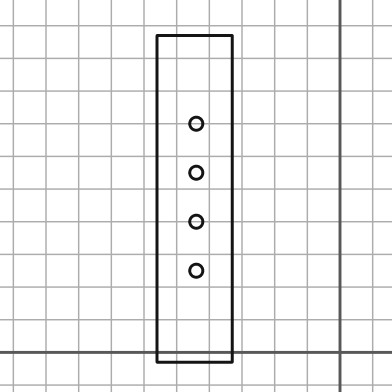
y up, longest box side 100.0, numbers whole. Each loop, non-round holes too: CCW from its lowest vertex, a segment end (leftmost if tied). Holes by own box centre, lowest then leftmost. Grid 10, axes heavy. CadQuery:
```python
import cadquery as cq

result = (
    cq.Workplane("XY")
    .moveTo(-56.0, -3.0)
    .lineTo(-33.0, -3.0)
    .lineTo(-33.0, 97.0)
    .lineTo(-56.0, 97.0)
    .close()
    .moveTo(-44.0, 25.0)
    .circle(2.0)
    .moveTo(-44.0, 40.0)
    .circle(2.0)
    .moveTo(-44.0, 55.0)
    .circle(2.0)
    .moveTo(-44.0, 70.0)
    .circle(2.0)
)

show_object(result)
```